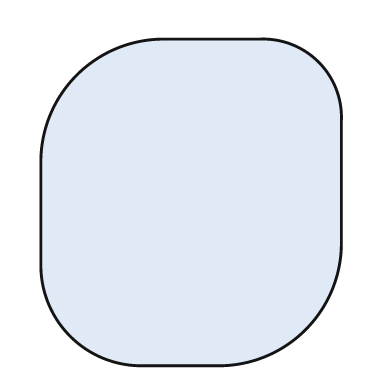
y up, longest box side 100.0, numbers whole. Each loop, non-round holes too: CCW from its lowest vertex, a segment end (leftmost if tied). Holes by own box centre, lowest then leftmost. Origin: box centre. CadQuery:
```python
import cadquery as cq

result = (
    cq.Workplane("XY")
    .moveTo(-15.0, -50.0)
    .lineTo(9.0, -50.0)
    .threePointArc((35.0, -39.0), (46.0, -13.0))
    .lineTo(46.0, 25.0)
    .threePointArc((39.0, 43.0), (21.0, 50.0))
    .lineTo(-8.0, 50.0)
    .threePointArc((-35.0, 39.0), (-46.0, 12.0))
    .lineTo(-46.0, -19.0)
    .threePointArc((-37.0, -41.0), (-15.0, -50.0))
    .close()
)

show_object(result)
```